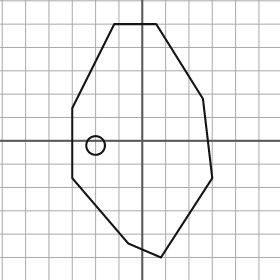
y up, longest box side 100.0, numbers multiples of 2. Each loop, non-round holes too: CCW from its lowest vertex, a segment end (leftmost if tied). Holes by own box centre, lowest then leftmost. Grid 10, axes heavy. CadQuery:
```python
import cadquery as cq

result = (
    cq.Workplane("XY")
    .moveTo(8.0, -50.0)
    .lineTo(30.0, -16.0)
    .lineTo(26.0, 18.0)
    .lineTo(6.0, 50.0)
    .lineTo(-12.0, 50.0)
    .lineTo(-30.0, 14.0)
    .lineTo(-30.0, -16.0)
    .lineTo(-6.0, -44.0)
    .close()
    .moveTo(-20.0, -2.0)
    .circle(4.0)
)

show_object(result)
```